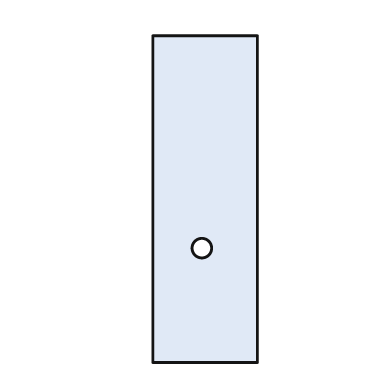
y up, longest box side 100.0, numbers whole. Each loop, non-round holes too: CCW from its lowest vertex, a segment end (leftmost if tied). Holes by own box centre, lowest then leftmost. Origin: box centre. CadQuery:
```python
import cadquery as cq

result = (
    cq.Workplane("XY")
    .moveTo(-16.0, -50.0)
    .lineTo(16.0, -50.0)
    .lineTo(16.0, 50.0)
    .lineTo(-16.0, 50.0)
    .close()
    .moveTo(-1.0, -15.0)
    .circle(3.0)
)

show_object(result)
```